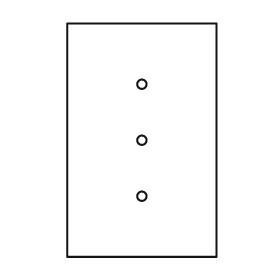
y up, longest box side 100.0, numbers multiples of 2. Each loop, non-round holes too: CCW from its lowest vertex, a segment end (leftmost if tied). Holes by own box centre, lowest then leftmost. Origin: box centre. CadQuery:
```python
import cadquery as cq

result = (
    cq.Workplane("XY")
    .moveTo(-32.0, -50.0)
    .lineTo(32.0, -50.0)
    .lineTo(32.0, 50.0)
    .lineTo(-32.0, 50.0)
    .close()
    .moveTo(0.0, -24.0)
    .circle(2.0)
    .moveTo(0.0, 0.0)
    .circle(2.0)
    .moveTo(0.0, 24.0)
    .circle(2.0)
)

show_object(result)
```